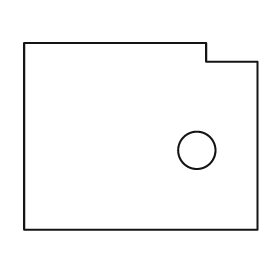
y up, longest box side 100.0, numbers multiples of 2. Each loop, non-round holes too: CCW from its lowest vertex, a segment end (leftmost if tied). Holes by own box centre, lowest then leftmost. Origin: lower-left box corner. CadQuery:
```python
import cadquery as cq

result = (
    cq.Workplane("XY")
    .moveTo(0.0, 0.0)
    .lineTo(100.0, 0.0)
    .lineTo(100.0, 72.0)
    .lineTo(78.0, 72.0)
    .lineTo(78.0, 80.0)
    .lineTo(0.0, 80.0)
    .close()
    .moveTo(74.0, 34.0)
    .circle(8.0)
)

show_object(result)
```